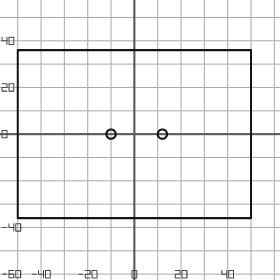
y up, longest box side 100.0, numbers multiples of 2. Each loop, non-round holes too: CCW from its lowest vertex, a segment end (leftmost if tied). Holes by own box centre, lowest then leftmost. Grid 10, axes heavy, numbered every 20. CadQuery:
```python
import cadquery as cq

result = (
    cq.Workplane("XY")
    .moveTo(-50.0, -36.0)
    .lineTo(50.0, -36.0)
    .lineTo(50.0, 36.0)
    .lineTo(-50.0, 36.0)
    .close()
    .moveTo(-10.0, 0.0)
    .circle(2.0)
    .moveTo(12.0, 0.0)
    .circle(2.0)
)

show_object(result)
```